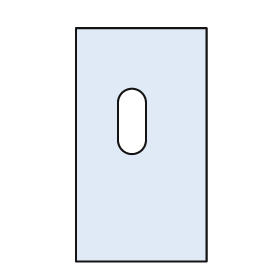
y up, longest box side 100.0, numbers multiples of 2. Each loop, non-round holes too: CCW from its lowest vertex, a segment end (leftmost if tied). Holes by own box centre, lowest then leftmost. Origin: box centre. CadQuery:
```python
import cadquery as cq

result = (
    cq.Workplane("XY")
    .moveTo(-28.0, -50.0)
    .lineTo(28.0, -50.0)
    .lineTo(28.0, 50.0)
    .lineTo(-28.0, 50.0)
    .close()
    .moveTo(-10.0, 2.0)
    .threePointArc((-4.0, -4.0), (2.0, 2.0))
    .lineTo(2.0, 18.0)
    .threePointArc((-4.0, 24.0), (-10.0, 18.0))
    .close()
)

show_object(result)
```